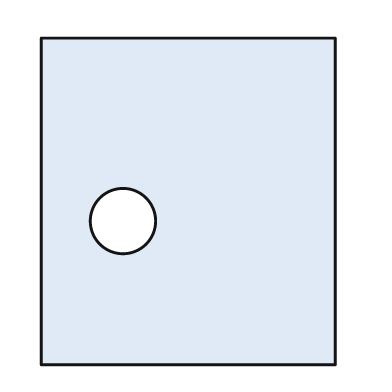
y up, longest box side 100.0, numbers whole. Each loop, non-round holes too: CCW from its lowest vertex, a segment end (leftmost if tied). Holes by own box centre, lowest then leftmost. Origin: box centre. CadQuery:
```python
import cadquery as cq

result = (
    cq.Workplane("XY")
    .moveTo(-45.0, -50.0)
    .lineTo(45.0, -50.0)
    .lineTo(45.0, 50.0)
    .lineTo(-45.0, 50.0)
    .close()
    .moveTo(-20.0, -6.0)
    .circle(10.0)
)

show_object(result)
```